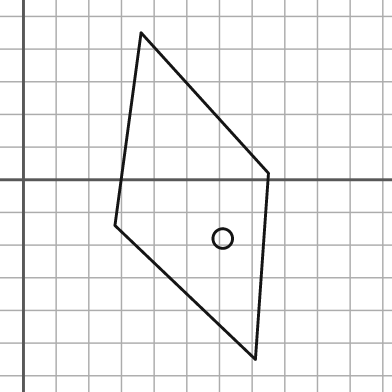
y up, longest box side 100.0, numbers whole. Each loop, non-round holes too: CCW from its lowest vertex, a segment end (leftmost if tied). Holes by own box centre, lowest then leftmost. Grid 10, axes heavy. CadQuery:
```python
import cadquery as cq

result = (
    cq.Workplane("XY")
    .moveTo(71.0, -55.0)
    .lineTo(75.0, 2.0)
    .lineTo(36.0, 45.0)
    .lineTo(28.0, -14.0)
    .close()
    .moveTo(61.0, -18.0)
    .circle(3.0)
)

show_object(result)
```